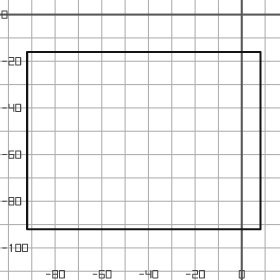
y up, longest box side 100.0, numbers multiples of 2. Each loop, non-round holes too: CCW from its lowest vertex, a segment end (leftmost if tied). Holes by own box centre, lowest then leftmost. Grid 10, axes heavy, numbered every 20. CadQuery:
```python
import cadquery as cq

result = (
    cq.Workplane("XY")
    .moveTo(-92.0, -92.0)
    .lineTo(8.0, -92.0)
    .lineTo(8.0, -16.0)
    .lineTo(-92.0, -16.0)
    .close()
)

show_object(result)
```